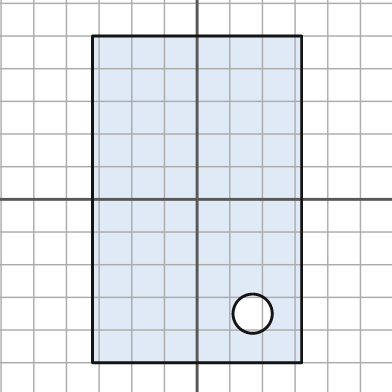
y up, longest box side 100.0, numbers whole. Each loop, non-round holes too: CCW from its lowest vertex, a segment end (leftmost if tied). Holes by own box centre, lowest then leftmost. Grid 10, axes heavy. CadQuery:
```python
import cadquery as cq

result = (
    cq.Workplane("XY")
    .moveTo(-32.0, -50.0)
    .lineTo(32.0, -50.0)
    .lineTo(32.0, 50.0)
    .lineTo(-32.0, 50.0)
    .close()
    .moveTo(17.0, -35.0)
    .circle(6.0)
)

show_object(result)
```